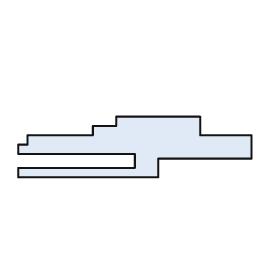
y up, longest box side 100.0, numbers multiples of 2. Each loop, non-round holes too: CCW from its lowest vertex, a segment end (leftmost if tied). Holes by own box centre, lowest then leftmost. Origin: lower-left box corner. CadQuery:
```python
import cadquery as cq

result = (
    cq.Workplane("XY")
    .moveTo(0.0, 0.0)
    .lineTo(60.0, 0.0)
    .lineTo(60.0, 8.0)
    .lineTo(100.0, 8.0)
    .lineTo(100.0, 18.0)
    .lineTo(78.0, 18.0)
    .lineTo(78.0, 26.0)
    .lineTo(42.0, 26.0)
    .lineTo(42.0, 22.0)
    .lineTo(32.0, 22.0)
    .lineTo(32.0, 18.0)
    .lineTo(4.0, 18.0)
    .lineTo(4.0, 14.0)
    .lineTo(0.0, 14.0)
    .lineTo(0.0, 10.0)
    .lineTo(50.0, 10.0)
    .lineTo(50.0, 4.0)
    .lineTo(0.0, 4.0)
    .close()
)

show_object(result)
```